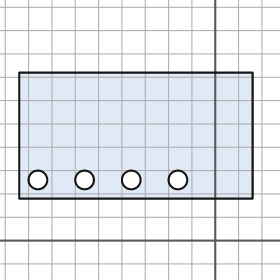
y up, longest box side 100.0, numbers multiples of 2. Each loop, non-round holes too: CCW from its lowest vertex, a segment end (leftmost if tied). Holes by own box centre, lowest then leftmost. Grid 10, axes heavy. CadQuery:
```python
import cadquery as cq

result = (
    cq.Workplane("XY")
    .moveTo(-84.0, 18.0)
    .lineTo(16.0, 18.0)
    .lineTo(16.0, 72.0)
    .lineTo(-84.0, 72.0)
    .close()
    .moveTo(-76.0, 26.0)
    .circle(4.0)
    .moveTo(-56.0, 26.0)
    .circle(4.0)
    .moveTo(-36.0, 26.0)
    .circle(4.0)
    .moveTo(-16.0, 26.0)
    .circle(4.0)
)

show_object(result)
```